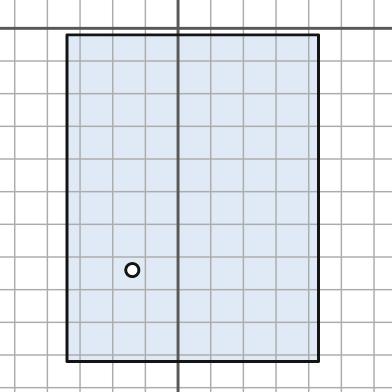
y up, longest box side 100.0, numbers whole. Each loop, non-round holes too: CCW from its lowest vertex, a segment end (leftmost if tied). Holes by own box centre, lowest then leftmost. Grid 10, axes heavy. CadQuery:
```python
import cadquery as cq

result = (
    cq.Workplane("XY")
    .moveTo(-34.0, -102.0)
    .lineTo(43.0, -102.0)
    .lineTo(43.0, -2.0)
    .lineTo(-34.0, -2.0)
    .close()
    .moveTo(-14.0, -74.0)
    .circle(2.0)
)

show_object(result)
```